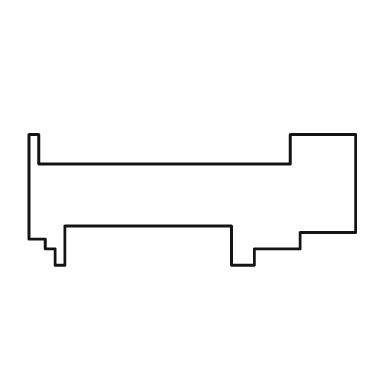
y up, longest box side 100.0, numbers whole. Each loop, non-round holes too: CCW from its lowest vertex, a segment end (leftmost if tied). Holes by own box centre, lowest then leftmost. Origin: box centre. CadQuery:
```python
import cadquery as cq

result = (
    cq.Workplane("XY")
    .moveTo(-42.0, -20.0)
    .lineTo(-39.0, -20.0)
    .lineTo(-39.0, -8.0)
    .lineTo(12.0, -8.0)
    .lineTo(12.0, -20.0)
    .lineTo(19.0, -20.0)
    .lineTo(19.0, -15.0)
    .lineTo(33.0, -15.0)
    .lineTo(33.0, -10.0)
    .lineTo(50.0, -10.0)
    .lineTo(50.0, 20.0)
    .lineTo(30.0, 20.0)
    .lineTo(30.0, 11.0)
    .lineTo(-47.0, 11.0)
    .lineTo(-47.0, 20.0)
    .lineTo(-50.0, 20.0)
    .lineTo(-50.0, -12.0)
    .lineTo(-45.0, -12.0)
    .lineTo(-45.0, -15.0)
    .lineTo(-42.0, -15.0)
    .close()
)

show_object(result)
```